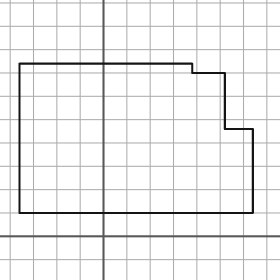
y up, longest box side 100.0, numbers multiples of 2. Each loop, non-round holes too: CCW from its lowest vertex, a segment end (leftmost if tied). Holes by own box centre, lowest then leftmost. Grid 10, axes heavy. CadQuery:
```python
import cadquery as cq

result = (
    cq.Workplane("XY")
    .moveTo(-36.0, 10.0)
    .lineTo(64.0, 10.0)
    .lineTo(64.0, 46.0)
    .lineTo(52.0, 46.0)
    .lineTo(52.0, 70.0)
    .lineTo(38.0, 70.0)
    .lineTo(38.0, 74.0)
    .lineTo(-36.0, 74.0)
    .close()
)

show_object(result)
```